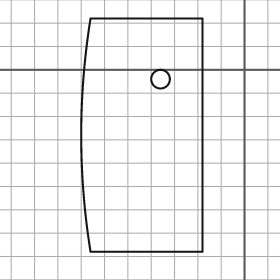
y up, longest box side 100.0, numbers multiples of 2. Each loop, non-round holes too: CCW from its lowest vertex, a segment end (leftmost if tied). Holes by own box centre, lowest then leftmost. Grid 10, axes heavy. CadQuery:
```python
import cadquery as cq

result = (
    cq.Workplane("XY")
    .moveTo(-66.0, -78.0)
    .lineTo(-18.0, -78.0)
    .lineTo(-18.0, 22.0)
    .lineTo(-66.0, 22.0)
    .threePointArc((-70.0, -28.0), (-66.0, -78.0))
    .close()
    .moveTo(-36.0, -4.0)
    .circle(4.0)
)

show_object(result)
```